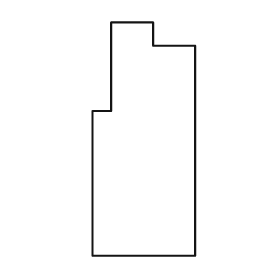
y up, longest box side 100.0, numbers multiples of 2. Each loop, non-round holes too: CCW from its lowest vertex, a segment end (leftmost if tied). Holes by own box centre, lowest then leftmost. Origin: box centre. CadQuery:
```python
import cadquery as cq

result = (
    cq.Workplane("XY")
    .moveTo(-22.0, -50.0)
    .lineTo(22.0, -50.0)
    .lineTo(22.0, 40.0)
    .lineTo(4.0, 40.0)
    .lineTo(4.0, 50.0)
    .lineTo(-14.0, 50.0)
    .lineTo(-14.0, 12.0)
    .lineTo(-22.0, 12.0)
    .close()
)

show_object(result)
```